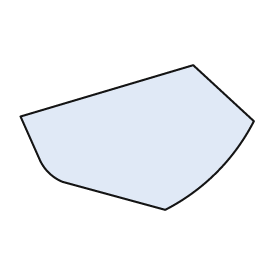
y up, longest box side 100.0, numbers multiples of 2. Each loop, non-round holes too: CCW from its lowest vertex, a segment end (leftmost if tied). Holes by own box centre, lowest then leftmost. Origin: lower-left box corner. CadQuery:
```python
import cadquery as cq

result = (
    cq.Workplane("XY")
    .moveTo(62.0, 0.0)
    .threePointArc((84.0, 16.0), (100.0, 38.0))
    .lineTo(74.0, 62.0)
    .lineTo(0.0, 40.0)
    .lineTo(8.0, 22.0)
    .threePointArc((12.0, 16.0), (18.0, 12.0))
    .close()
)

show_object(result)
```